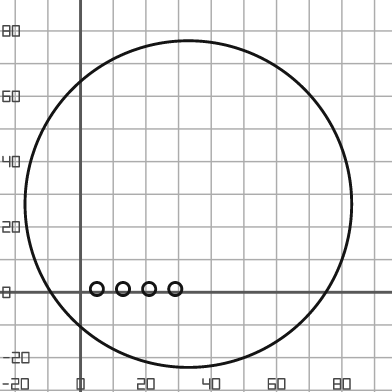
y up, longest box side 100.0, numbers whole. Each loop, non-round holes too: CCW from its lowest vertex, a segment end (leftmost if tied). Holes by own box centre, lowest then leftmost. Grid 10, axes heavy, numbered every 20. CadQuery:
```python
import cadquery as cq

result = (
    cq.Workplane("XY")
    .moveTo(33.0, 27.0)
    .circle(50.0)
    .moveTo(5.0, 1.0)
    .circle(2.0)
    .moveTo(13.0, 1.0)
    .circle(2.0)
    .moveTo(21.0, 1.0)
    .circle(2.0)
    .moveTo(29.0, 1.0)
    .circle(2.0)
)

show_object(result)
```